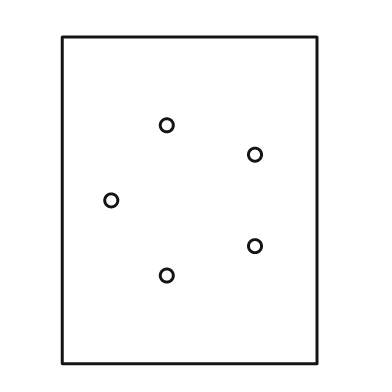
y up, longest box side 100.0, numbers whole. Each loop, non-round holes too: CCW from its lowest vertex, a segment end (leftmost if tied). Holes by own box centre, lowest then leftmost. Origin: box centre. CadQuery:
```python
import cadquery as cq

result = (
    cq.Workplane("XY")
    .moveTo(-39.0, -50.0)
    .lineTo(39.0, -50.0)
    .lineTo(39.0, 50.0)
    .lineTo(-39.0, 50.0)
    .close()
    .moveTo(-7.0, -23.0)
    .circle(2.0)
    .moveTo(20.0, -14.0)
    .circle(2.0)
    .moveTo(-24.0, 0.0)
    .circle(2.0)
    .moveTo(20.0, 14.0)
    .circle(2.0)
    .moveTo(-7.0, 23.0)
    .circle(2.0)
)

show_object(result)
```